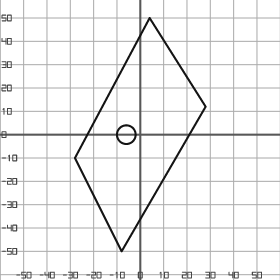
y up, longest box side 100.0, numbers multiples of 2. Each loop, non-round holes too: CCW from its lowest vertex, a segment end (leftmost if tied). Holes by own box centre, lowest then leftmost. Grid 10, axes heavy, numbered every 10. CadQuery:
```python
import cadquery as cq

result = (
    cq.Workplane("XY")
    .moveTo(-8.0, -50.0)
    .lineTo(28.0, 12.0)
    .lineTo(4.0, 50.0)
    .lineTo(-28.0, -10.0)
    .close()
    .moveTo(-6.0, 0.0)
    .circle(4.0)
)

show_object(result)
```